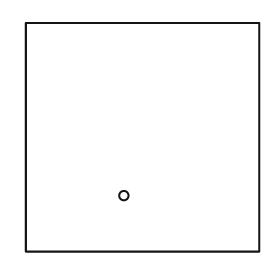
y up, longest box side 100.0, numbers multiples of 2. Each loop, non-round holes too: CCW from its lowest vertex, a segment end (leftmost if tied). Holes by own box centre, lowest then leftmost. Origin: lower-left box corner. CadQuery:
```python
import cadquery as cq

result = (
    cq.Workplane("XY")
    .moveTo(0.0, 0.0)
    .lineTo(100.0, 0.0)
    .lineTo(100.0, 98.0)
    .lineTo(0.0, 98.0)
    .close()
    .moveTo(42.0, 24.0)
    .circle(2.0)
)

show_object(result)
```